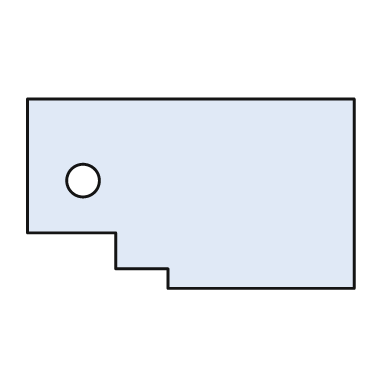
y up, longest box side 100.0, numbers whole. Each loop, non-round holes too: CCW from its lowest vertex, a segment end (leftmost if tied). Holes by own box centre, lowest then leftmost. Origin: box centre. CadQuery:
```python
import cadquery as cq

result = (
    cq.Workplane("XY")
    .moveTo(-7.0, -29.0)
    .lineTo(50.0, -29.0)
    .lineTo(50.0, 29.0)
    .lineTo(-50.0, 29.0)
    .lineTo(-50.0, -12.0)
    .lineTo(-23.0, -12.0)
    .lineTo(-23.0, -23.0)
    .lineTo(-7.0, -23.0)
    .close()
    .moveTo(-33.0, 4.0)
    .circle(5.0)
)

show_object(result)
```